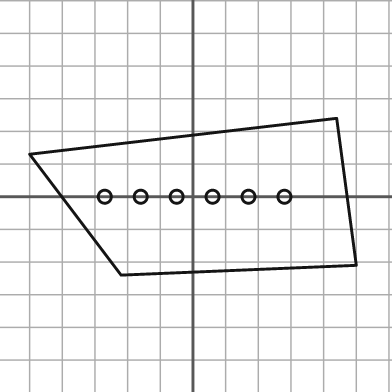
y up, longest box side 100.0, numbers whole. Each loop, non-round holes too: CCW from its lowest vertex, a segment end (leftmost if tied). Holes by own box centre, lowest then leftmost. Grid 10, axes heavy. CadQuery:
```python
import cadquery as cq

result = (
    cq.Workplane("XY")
    .moveTo(-22.0, -24.0)
    .lineTo(50.0, -21.0)
    .lineTo(44.0, 24.0)
    .lineTo(-50.0, 13.0)
    .close()
    .moveTo(-27.0, 0.0)
    .circle(2.0)
    .moveTo(-16.0, 0.0)
    .circle(2.0)
    .moveTo(-5.0, 0.0)
    .circle(2.0)
    .moveTo(6.0, 0.0)
    .circle(2.0)
    .moveTo(17.0, 0.0)
    .circle(2.0)
    .moveTo(28.0, 0.0)
    .circle(2.0)
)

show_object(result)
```